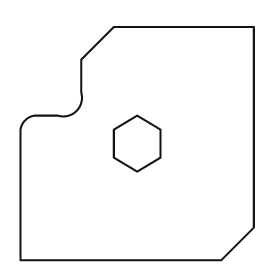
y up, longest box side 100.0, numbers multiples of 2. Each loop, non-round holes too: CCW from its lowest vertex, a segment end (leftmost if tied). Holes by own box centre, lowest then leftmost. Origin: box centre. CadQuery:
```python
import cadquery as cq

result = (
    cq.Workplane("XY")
    .moveTo(-50.0, -50.0)
    .lineTo(36.0, -50.0)
    .lineTo(50.0, -36.0)
    .lineTo(50.0, 50.0)
    .lineTo(-10.0, 50.0)
    .lineTo(-24.0, 36.0)
    .lineTo(-24.0, 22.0)
    .threePointArc((-26.0, 14.0), (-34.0, 12.0))
    .lineTo(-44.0, 12.0)
    .threePointArc((-48.0, 10.0), (-50.0, 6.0))
    .close()
    .moveTo(0.0, -12.0)
    .lineTo(10.0, -6.0)
    .lineTo(10.0, 6.0)
    .lineTo(0.0, 12.0)
    .lineTo(-10.0, 6.0)
    .lineTo(-10.0, -6.0)
    .close()
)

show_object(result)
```